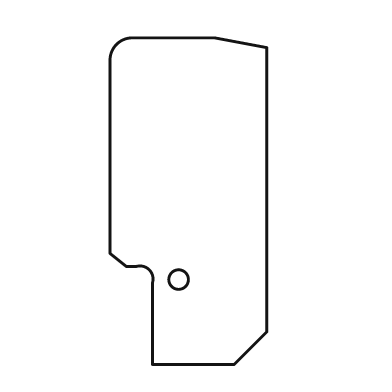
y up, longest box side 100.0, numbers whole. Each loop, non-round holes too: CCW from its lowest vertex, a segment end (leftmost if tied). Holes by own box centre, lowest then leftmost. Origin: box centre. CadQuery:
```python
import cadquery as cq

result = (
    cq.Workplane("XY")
    .moveTo(-11.0, -50.0)
    .lineTo(14.0, -50.0)
    .lineTo(24.0, -40.0)
    .lineTo(24.0, 47.0)
    .lineTo(8.0, 50.0)
    .lineTo(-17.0, 50.0)
    .threePointArc((-22.0, 48.0), (-24.0, 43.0))
    .lineTo(-24.0, -16.0)
    .lineTo(-19.0, -20.0)
    .lineTo(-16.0, -20.0)
    .threePointArc((-12.0, -21.0), (-11.0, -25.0))
    .close()
    .moveTo(-3.0, -24.0)
    .circle(3.0)
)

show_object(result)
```